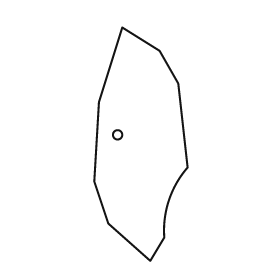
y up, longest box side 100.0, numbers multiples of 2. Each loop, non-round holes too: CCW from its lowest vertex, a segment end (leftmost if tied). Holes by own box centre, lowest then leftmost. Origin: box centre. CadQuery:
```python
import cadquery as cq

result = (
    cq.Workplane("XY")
    .moveTo(4.0, -50.0)
    .lineTo(10.0, -40.0)
    .threePointArc((12.0, -24.0), (20.0, -10.0))
    .lineTo(16.0, 26.0)
    .lineTo(8.0, 40.0)
    .lineTo(-8.0, 50.0)
    .lineTo(-18.0, 18.0)
    .lineTo(-20.0, -16.0)
    .lineTo(-14.0, -34.0)
    .close()
    .moveTo(-10.0, 4.0)
    .circle(2.0)
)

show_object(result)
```